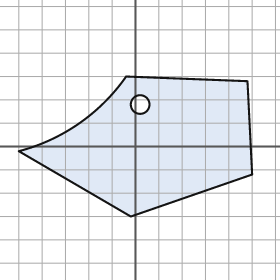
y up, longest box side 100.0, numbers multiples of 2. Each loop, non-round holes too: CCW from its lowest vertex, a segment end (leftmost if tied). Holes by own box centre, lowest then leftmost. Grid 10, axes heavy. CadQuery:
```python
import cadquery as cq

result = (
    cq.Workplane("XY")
    .moveTo(-2.0, -30.0)
    .lineTo(50.0, -12.0)
    .lineTo(48.0, 28.0)
    .lineTo(-4.0, 30.0)
    .threePointArc((-24.0, 10.0), (-50.0, -2.0))
    .close()
    .moveTo(2.0, 18.0)
    .circle(4.0)
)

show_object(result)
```